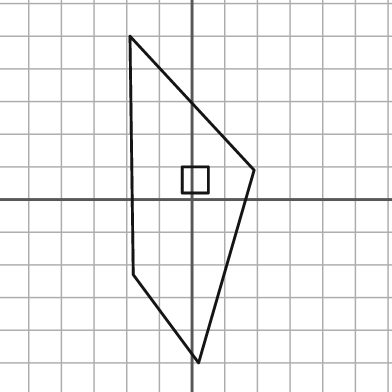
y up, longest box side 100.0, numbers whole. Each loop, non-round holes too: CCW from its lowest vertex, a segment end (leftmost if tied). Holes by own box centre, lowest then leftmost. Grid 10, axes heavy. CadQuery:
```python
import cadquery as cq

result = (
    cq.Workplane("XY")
    .moveTo(2.0, -50.0)
    .lineTo(19.0, 9.0)
    .lineTo(-19.0, 50.0)
    .lineTo(-18.0, -23.0)
    .close()
    .moveTo(-3.0, 2.0)
    .lineTo(5.0, 2.0)
    .lineTo(5.0, 10.0)
    .lineTo(-3.0, 10.0)
    .close()
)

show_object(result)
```